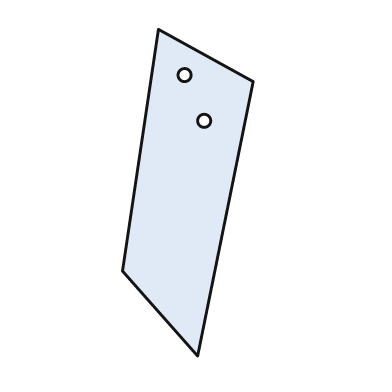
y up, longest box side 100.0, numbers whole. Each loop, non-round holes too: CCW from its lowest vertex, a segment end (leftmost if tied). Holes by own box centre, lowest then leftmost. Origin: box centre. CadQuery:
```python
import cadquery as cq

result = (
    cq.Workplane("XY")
    .moveTo(3.0, -50.0)
    .lineTo(20.0, 34.0)
    .lineTo(-9.0, 50.0)
    .lineTo(-20.0, -24.0)
    .close()
    .moveTo(5.0, 22.0)
    .circle(2.0)
    .moveTo(-1.0, 36.0)
    .circle(2.0)
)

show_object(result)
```